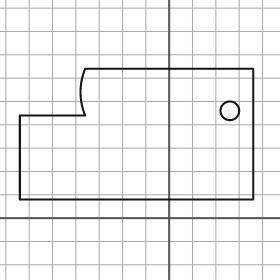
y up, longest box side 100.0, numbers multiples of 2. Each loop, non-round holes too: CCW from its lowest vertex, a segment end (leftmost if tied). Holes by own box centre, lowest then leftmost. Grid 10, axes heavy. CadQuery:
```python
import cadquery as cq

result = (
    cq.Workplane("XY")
    .moveTo(-64.0, 8.0)
    .lineTo(36.0, 8.0)
    .lineTo(36.0, 64.0)
    .lineTo(-36.0, 64.0)
    .threePointArc((-38.0, 54.0), (-36.0, 44.0))
    .lineTo(-64.0, 44.0)
    .close()
    .moveTo(26.0, 46.0)
    .circle(4.0)
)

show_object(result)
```